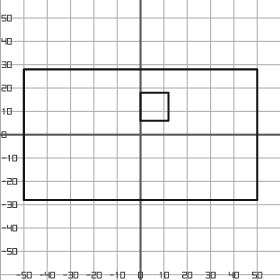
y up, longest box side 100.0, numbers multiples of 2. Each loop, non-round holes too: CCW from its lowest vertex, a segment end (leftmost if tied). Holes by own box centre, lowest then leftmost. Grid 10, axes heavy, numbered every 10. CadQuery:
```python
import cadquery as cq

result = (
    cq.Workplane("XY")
    .moveTo(-50.0, -28.0)
    .lineTo(50.0, -28.0)
    .lineTo(50.0, 28.0)
    .lineTo(-50.0, 28.0)
    .close()
    .moveTo(0.0, 6.0)
    .lineTo(12.0, 6.0)
    .lineTo(12.0, 18.0)
    .lineTo(0.0, 18.0)
    .close()
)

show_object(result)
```